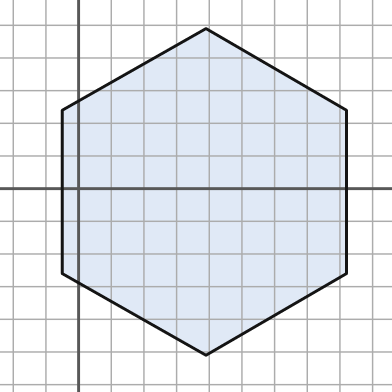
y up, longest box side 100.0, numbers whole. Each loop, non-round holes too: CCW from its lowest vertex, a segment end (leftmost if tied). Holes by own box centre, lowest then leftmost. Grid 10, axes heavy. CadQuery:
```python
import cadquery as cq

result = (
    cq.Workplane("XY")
    .moveTo(39.0, -51.0)
    .lineTo(82.0, -26.0)
    .lineTo(82.0, 24.0)
    .lineTo(39.0, 49.0)
    .lineTo(-5.0, 24.0)
    .lineTo(-5.0, -26.0)
    .close()
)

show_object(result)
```